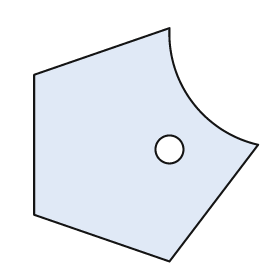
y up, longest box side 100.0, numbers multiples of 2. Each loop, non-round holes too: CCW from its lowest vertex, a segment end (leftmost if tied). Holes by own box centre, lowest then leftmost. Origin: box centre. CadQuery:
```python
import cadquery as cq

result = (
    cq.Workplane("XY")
    .moveTo(10.0, -50.0)
    .lineTo(48.0, 0.0)
    .threePointArc((20.0, 18.0), (10.0, 50.0))
    .lineTo(-48.0, 30.0)
    .lineTo(-48.0, -30.0)
    .close()
    .moveTo(10.0, -2.0)
    .circle(6.0)
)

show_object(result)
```